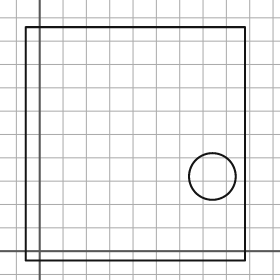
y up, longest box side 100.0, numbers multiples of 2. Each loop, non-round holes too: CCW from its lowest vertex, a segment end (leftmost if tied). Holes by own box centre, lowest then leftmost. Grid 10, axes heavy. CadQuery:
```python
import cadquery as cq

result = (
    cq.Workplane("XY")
    .moveTo(-6.0, -4.0)
    .lineTo(88.0, -4.0)
    .lineTo(88.0, 96.0)
    .lineTo(-6.0, 96.0)
    .close()
    .moveTo(74.0, 32.0)
    .circle(10.0)
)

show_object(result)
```